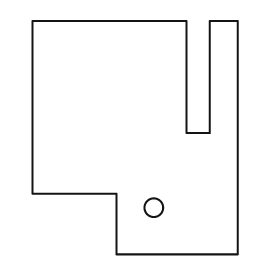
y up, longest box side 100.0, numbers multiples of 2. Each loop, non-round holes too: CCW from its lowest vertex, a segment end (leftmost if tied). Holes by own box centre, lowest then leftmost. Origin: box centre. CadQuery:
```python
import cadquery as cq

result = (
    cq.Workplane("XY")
    .moveTo(-8.0, -50.0)
    .lineTo(44.0, -50.0)
    .lineTo(44.0, 50.0)
    .lineTo(32.0, 50.0)
    .lineTo(32.0, 2.0)
    .lineTo(22.0, 2.0)
    .lineTo(22.0, 50.0)
    .lineTo(-44.0, 50.0)
    .lineTo(-44.0, -24.0)
    .lineTo(-8.0, -24.0)
    .close()
    .moveTo(8.0, -30.0)
    .circle(4.0)
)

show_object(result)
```